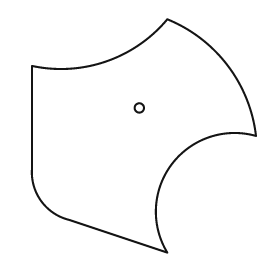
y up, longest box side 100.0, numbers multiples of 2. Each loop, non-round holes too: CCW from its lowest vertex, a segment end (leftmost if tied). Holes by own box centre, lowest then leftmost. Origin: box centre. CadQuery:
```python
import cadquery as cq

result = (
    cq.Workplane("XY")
    .moveTo(10.0, -50.0)
    .threePointArc((12.0, -12.0), (48.0, 0.0))
    .threePointArc((36.0, 30.0), (10.0, 50.0))
    .threePointArc((-16.0, 32.0), (-48.0, 30.0))
    .lineTo(-48.0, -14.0)
    .threePointArc((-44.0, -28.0), (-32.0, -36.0))
    .close()
    .moveTo(-2.0, 12.0)
    .circle(2.0)
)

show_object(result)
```